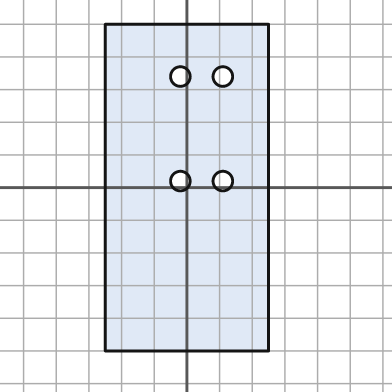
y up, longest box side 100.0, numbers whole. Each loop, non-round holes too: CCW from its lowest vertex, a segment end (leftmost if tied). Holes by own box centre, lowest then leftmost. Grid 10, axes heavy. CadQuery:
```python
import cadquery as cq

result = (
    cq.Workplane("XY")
    .moveTo(-25.0, -50.0)
    .lineTo(25.0, -50.0)
    .lineTo(25.0, 50.0)
    .lineTo(-25.0, 50.0)
    .close()
    .moveTo(-2.0, 2.0)
    .circle(3.0)
    .moveTo(11.0, 2.0)
    .circle(3.0)
    .moveTo(-2.0, 34.0)
    .circle(3.0)
    .moveTo(11.0, 34.0)
    .circle(3.0)
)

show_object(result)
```